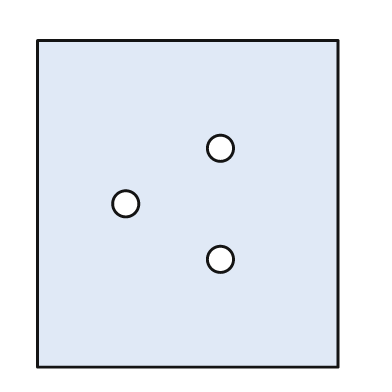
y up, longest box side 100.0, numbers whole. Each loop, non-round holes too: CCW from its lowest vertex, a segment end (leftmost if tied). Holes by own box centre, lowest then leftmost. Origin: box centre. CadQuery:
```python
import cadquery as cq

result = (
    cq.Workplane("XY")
    .moveTo(-46.0, -50.0)
    .lineTo(46.0, -50.0)
    .lineTo(46.0, 50.0)
    .lineTo(-46.0, 50.0)
    .close()
    .moveTo(10.0, -17.0)
    .circle(4.0)
    .moveTo(-19.0, 0.0)
    .circle(4.0)
    .moveTo(10.0, 17.0)
    .circle(4.0)
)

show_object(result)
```